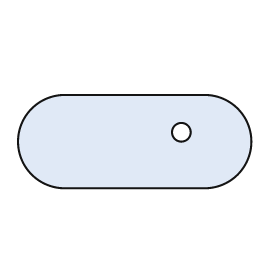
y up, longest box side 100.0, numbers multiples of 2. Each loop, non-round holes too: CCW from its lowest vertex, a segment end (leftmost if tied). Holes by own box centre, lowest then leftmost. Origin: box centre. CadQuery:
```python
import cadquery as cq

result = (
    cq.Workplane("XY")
    .moveTo(-30.0, -20.0)
    .lineTo(30.0, -20.0)
    .threePointArc((50.0, 0.0), (30.0, 20.0))
    .lineTo(-30.0, 20.0)
    .threePointArc((-50.0, 0.0), (-30.0, -20.0))
    .close()
    .moveTo(20.0, 4.0)
    .circle(4.0)
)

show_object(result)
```